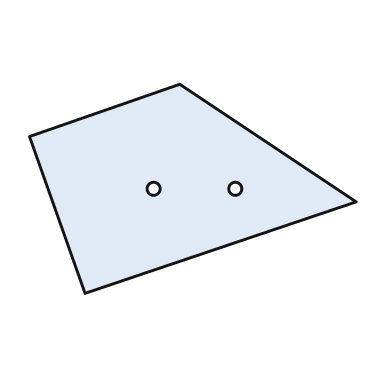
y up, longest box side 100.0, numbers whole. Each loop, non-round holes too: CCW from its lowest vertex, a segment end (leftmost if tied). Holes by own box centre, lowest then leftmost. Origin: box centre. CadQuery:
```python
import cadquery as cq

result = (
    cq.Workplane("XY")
    .moveTo(-33.0, -32.0)
    .lineTo(50.0, -4.0)
    .lineTo(-4.0, 32.0)
    .lineTo(-50.0, 16.0)
    .close()
    .moveTo(-12.0, 0.0)
    .circle(2.0)
    .moveTo(13.0, 0.0)
    .circle(2.0)
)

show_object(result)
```